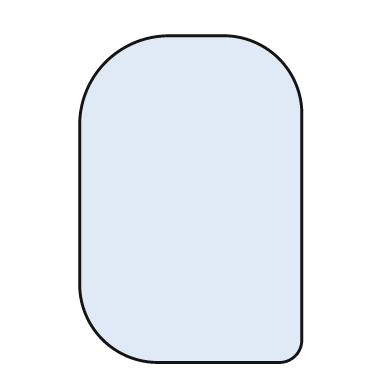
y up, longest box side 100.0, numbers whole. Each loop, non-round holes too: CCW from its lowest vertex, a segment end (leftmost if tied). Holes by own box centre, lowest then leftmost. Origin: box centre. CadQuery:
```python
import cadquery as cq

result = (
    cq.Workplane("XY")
    .moveTo(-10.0, -50.0)
    .lineTo(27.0, -50.0)
    .threePointArc((32.0, -48.0), (34.0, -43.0))
    .lineTo(34.0, 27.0)
    .threePointArc((27.0, 43.0), (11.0, 50.0))
    .lineTo(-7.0, 50.0)
    .threePointArc((-26.0, 42.0), (-34.0, 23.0))
    .lineTo(-34.0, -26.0)
    .threePointArc((-27.0, -43.0), (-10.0, -50.0))
    .close()
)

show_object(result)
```